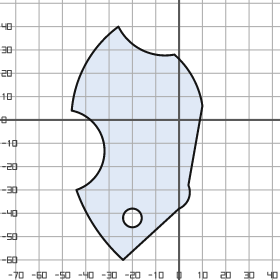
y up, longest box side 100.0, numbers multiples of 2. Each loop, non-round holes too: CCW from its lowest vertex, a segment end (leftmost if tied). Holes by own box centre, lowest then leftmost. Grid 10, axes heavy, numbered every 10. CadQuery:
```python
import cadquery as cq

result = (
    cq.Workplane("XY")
    .moveTo(-24.0, -60.0)
    .lineTo(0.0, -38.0)
    .threePointArc((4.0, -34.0), (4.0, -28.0))
    .lineTo(10.0, 6.0)
    .threePointArc((6.0, 18.0), (-2.0, 28.0))
    .threePointArc((-16.0, 30.0), (-26.0, 40.0))
    .threePointArc((-40.0, 24.0), (-46.0, 4.0))
    .threePointArc((-32.0, -12.0), (-44.0, -30.0))
    .threePointArc((-36.0, -46.0), (-24.0, -60.0))
    .close()
    .moveTo(-20.0, -42.0)
    .circle(4.0)
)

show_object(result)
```